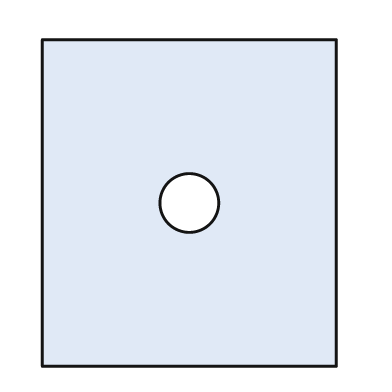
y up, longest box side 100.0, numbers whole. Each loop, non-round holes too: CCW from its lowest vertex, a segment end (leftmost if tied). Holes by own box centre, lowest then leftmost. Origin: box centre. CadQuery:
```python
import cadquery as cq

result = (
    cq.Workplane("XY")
    .moveTo(-45.0, -50.0)
    .lineTo(45.0, -50.0)
    .lineTo(45.0, 50.0)
    .lineTo(-45.0, 50.0)
    .close()
    .moveTo(0.0, 0.0)
    .circle(9.0)
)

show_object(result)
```